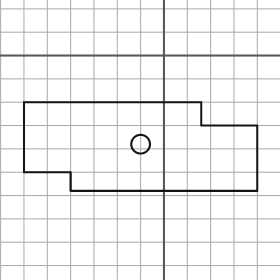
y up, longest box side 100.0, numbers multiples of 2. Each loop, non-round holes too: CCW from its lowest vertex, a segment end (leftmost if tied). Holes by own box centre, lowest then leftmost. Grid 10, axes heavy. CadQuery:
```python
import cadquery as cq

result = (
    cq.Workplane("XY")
    .moveTo(-40.0, -58.0)
    .lineTo(40.0, -58.0)
    .lineTo(40.0, -30.0)
    .lineTo(16.0, -30.0)
    .lineTo(16.0, -20.0)
    .lineTo(-60.0, -20.0)
    .lineTo(-60.0, -50.0)
    .lineTo(-40.0, -50.0)
    .close()
    .moveTo(-10.0, -38.0)
    .circle(4.0)
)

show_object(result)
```